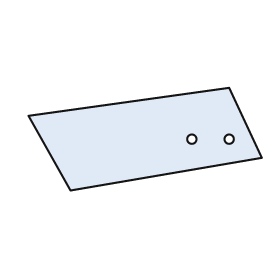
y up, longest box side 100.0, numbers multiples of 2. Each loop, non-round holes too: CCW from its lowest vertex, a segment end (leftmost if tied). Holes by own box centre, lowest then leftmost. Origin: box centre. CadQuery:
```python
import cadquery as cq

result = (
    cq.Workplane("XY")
    .moveTo(-32.0, -22.0)
    .lineTo(50.0, -8.0)
    .lineTo(36.0, 22.0)
    .lineTo(-50.0, 10.0)
    .close()
    .moveTo(20.0, 0.0)
    .circle(2.0)
    .moveTo(36.0, 0.0)
    .circle(2.0)
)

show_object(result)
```